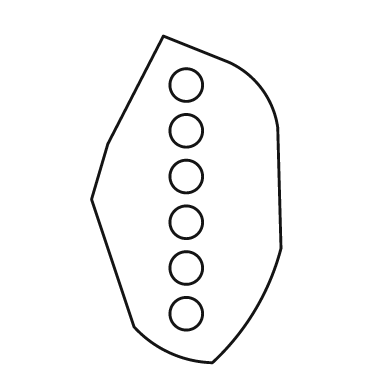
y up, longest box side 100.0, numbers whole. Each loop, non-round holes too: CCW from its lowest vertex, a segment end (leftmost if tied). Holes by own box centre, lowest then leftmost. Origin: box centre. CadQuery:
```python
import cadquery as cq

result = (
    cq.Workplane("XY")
    .moveTo(8.0, -50.0)
    .threePointArc((21.0, -34.0), (29.0, -15.0))
    .lineTo(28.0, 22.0)
    .threePointArc((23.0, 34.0), (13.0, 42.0))
    .lineTo(-7.0, 50.0)
    .lineTo(-24.0, 17.0)
    .lineTo(-29.0, 0.0)
    .lineTo(-16.0, -39.0)
    .threePointArc((-5.0, -47.0), (8.0, -50.0))
    .close()
    .moveTo(0.0, -35.0)
    .circle(5.0)
    .moveTo(0.0, -21.0)
    .circle(5.0)
    .moveTo(0.0, -7.0)
    .circle(5.0)
    .moveTo(0.0, 7.0)
    .circle(5.0)
    .moveTo(0.0, 21.0)
    .circle(5.0)
    .moveTo(0.0, 35.0)
    .circle(5.0)
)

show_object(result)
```